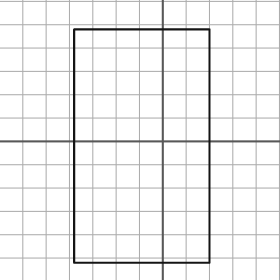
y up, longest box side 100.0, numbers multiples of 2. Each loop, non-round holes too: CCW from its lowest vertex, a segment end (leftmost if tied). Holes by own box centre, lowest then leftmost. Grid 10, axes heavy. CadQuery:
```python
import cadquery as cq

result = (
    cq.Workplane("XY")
    .moveTo(-38.0, -52.0)
    .lineTo(20.0, -52.0)
    .lineTo(20.0, 48.0)
    .lineTo(-38.0, 48.0)
    .close()
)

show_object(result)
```